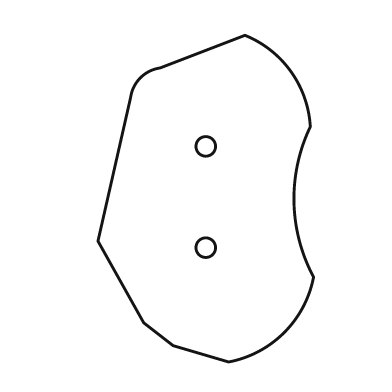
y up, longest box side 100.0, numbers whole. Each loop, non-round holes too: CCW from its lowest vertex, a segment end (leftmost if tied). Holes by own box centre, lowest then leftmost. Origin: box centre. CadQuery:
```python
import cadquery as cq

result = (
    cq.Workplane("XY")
    .moveTo(7.0, -50.0)
    .threePointArc((24.0, -41.0), (33.0, -24.0))
    .threePointArc((27.0, -1.0), (32.0, 22.0))
    .threePointArc((26.0, 39.0), (12.0, 50.0))
    .lineTo(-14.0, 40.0)
    .threePointArc((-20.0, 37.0), (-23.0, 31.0))
    .lineTo(-33.0, -13.0)
    .lineTo(-19.0, -38.0)
    .lineTo(-10.0, -45.0)
    .close()
    .moveTo(0.0, -15.0)
    .circle(3.0)
    .moveTo(0.0, 16.0)
    .circle(3.0)
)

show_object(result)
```